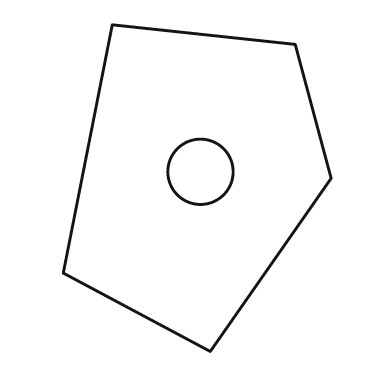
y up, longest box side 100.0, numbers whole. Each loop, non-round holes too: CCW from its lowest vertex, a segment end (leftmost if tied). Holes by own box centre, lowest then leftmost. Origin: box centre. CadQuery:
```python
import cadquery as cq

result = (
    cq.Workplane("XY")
    .moveTo(4.0, -50.0)
    .lineTo(41.0, 3.0)
    .lineTo(30.0, 44.0)
    .lineTo(-26.0, 50.0)
    .lineTo(-41.0, -26.0)
    .close()
    .moveTo(1.0, 5.0)
    .circle(10.0)
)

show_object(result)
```